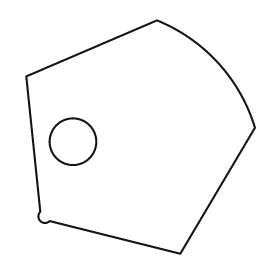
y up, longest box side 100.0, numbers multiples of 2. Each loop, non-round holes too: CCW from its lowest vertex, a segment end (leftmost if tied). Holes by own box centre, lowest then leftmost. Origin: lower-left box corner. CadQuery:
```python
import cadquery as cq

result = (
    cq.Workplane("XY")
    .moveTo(66.0, 0.0)
    .lineTo(98.0, 54.0)
    .threePointArc((82.0, 82.0), (56.0, 100.0))
    .lineTo(0.0, 76.0)
    .lineTo(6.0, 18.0)
    .threePointArc((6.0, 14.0), (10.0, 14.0))
    .close()
    .moveTo(20.0, 48.0)
    .circle(10.0)
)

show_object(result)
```